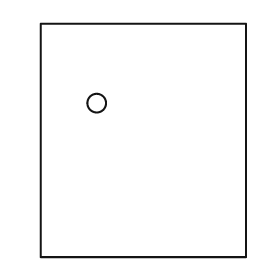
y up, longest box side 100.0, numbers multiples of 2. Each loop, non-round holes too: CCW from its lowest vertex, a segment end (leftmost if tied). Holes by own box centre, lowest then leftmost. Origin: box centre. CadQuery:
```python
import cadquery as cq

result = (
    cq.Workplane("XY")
    .moveTo(-44.0, -50.0)
    .lineTo(44.0, -50.0)
    .lineTo(44.0, 50.0)
    .lineTo(-44.0, 50.0)
    .close()
    .moveTo(-20.0, 16.0)
    .circle(4.0)
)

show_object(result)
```